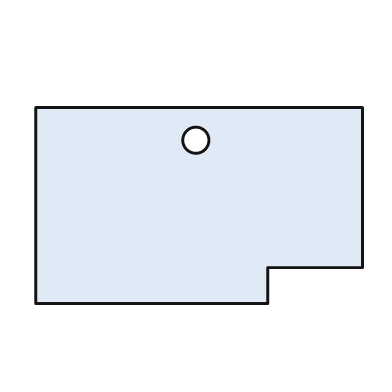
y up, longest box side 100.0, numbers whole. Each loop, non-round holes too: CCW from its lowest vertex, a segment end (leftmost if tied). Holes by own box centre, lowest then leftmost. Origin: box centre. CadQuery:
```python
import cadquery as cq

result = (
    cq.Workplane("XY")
    .moveTo(-50.0, -30.0)
    .lineTo(21.0, -30.0)
    .lineTo(21.0, -19.0)
    .lineTo(50.0, -19.0)
    .lineTo(50.0, 30.0)
    .lineTo(-50.0, 30.0)
    .close()
    .moveTo(-1.0, 20.0)
    .circle(4.0)
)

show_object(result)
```